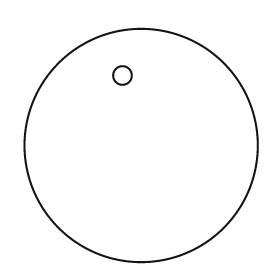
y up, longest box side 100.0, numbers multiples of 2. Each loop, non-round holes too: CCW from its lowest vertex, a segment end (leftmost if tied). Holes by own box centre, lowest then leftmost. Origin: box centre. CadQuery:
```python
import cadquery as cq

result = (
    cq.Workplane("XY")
    .moveTo(0.0, 0.0)
    .circle(50.0)
    .moveTo(-8.0, 30.0)
    .circle(4.0)
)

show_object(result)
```